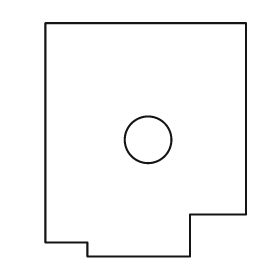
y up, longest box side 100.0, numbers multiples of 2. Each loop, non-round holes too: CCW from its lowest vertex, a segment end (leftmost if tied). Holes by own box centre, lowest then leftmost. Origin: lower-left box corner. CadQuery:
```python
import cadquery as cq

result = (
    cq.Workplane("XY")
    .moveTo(18.0, 0.0)
    .lineTo(62.0, 0.0)
    .lineTo(62.0, 18.0)
    .lineTo(86.0, 18.0)
    .lineTo(86.0, 100.0)
    .lineTo(0.0, 100.0)
    .lineTo(0.0, 6.0)
    .lineTo(18.0, 6.0)
    .close()
    .moveTo(44.0, 50.0)
    .circle(10.0)
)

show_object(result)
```